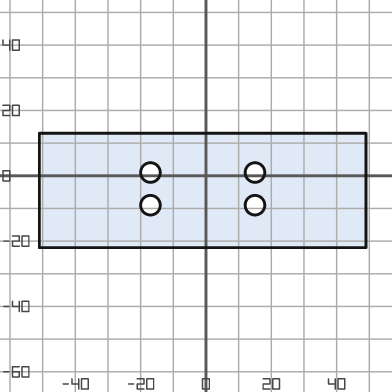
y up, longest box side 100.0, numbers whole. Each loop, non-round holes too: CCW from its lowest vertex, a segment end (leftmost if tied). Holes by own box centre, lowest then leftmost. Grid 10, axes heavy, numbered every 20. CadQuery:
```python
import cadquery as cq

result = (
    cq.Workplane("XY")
    .moveTo(-51.0, -22.0)
    .lineTo(49.0, -22.0)
    .lineTo(49.0, 13.0)
    .lineTo(-51.0, 13.0)
    .close()
    .moveTo(-17.0, -9.0)
    .circle(3.0)
    .moveTo(15.0, -9.0)
    .circle(3.0)
    .moveTo(-17.0, 1.0)
    .circle(3.0)
    .moveTo(15.0, 1.0)
    .circle(3.0)
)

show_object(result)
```